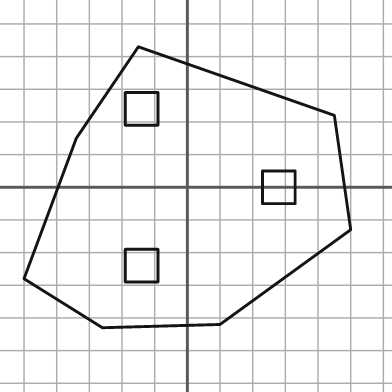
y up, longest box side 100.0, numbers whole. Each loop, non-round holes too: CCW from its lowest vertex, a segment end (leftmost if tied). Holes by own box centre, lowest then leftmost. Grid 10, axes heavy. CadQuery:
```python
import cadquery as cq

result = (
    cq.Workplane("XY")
    .moveTo(-26.0, -43.0)
    .lineTo(10.0, -42.0)
    .lineTo(50.0, -13.0)
    .lineTo(45.0, 22.0)
    .lineTo(-15.0, 43.0)
    .lineTo(-34.0, 15.0)
    .lineTo(-50.0, -28.0)
    .close()
    .moveTo(-19.0, -29.0)
    .lineTo(-9.0, -29.0)
    .lineTo(-9.0, -19.0)
    .lineTo(-19.0, -19.0)
    .close()
    .moveTo(23.0, -5.0)
    .lineTo(33.0, -5.0)
    .lineTo(33.0, 5.0)
    .lineTo(23.0, 5.0)
    .close()
    .moveTo(-19.0, 19.0)
    .lineTo(-9.0, 19.0)
    .lineTo(-9.0, 29.0)
    .lineTo(-19.0, 29.0)
    .close()
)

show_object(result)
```